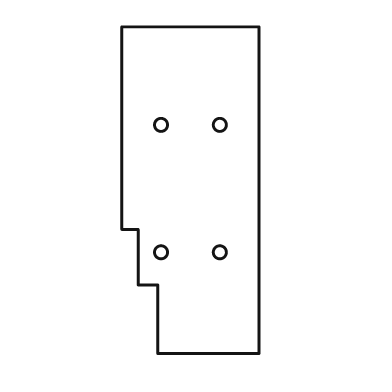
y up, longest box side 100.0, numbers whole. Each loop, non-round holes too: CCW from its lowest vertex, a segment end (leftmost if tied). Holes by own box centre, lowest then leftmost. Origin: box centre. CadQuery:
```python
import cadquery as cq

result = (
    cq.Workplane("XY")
    .moveTo(-10.0, -50.0)
    .lineTo(21.0, -50.0)
    .lineTo(21.0, 50.0)
    .lineTo(-21.0, 50.0)
    .lineTo(-21.0, -12.0)
    .lineTo(-16.0, -12.0)
    .lineTo(-16.0, -29.0)
    .lineTo(-10.0, -29.0)
    .close()
    .moveTo(-9.0, -19.0)
    .circle(2.0)
    .moveTo(9.0, -19.0)
    .circle(2.0)
    .moveTo(-9.0, 20.0)
    .circle(2.0)
    .moveTo(9.0, 20.0)
    .circle(2.0)
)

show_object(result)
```